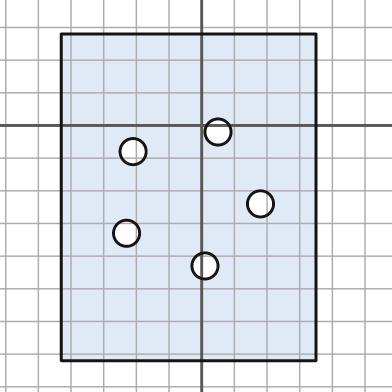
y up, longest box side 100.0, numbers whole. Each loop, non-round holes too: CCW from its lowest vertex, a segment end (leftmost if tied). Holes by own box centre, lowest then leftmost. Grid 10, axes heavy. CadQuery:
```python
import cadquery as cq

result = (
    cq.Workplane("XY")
    .moveTo(-43.0, -72.0)
    .lineTo(35.0, -72.0)
    .lineTo(35.0, 28.0)
    .lineTo(-43.0, 28.0)
    .close()
    .moveTo(1.0, -43.0)
    .circle(4.0)
    .moveTo(-23.0, -33.0)
    .circle(4.0)
    .moveTo(18.0, -24.0)
    .circle(4.0)
    .moveTo(-21.0, -8.0)
    .circle(4.0)
    .moveTo(5.0, -2.0)
    .circle(4.0)
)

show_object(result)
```